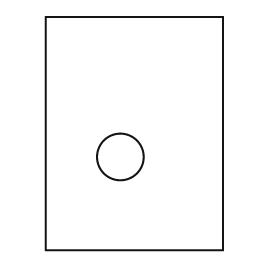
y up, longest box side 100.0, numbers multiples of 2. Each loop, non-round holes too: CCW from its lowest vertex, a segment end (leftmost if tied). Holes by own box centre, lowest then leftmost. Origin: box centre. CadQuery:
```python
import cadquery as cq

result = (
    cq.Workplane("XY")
    .moveTo(-38.0, -50.0)
    .lineTo(38.0, -50.0)
    .lineTo(38.0, 50.0)
    .lineTo(-38.0, 50.0)
    .close()
    .moveTo(-6.0, -10.0)
    .circle(10.0)
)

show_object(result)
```